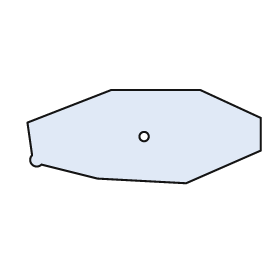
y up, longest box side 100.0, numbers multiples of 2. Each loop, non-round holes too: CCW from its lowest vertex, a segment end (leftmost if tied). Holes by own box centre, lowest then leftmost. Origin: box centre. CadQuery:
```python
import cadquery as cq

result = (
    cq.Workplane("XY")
    .moveTo(18.0, -20.0)
    .lineTo(50.0, -6.0)
    .lineTo(50.0, 8.0)
    .lineTo(24.0, 20.0)
    .lineTo(-14.0, 20.0)
    .lineTo(-50.0, 6.0)
    .lineTo(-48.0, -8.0)
    .threePointArc((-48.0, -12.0), (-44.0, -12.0))
    .lineTo(-20.0, -18.0)
    .close()
    .moveTo(0.0, 0.0)
    .circle(2.0)
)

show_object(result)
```